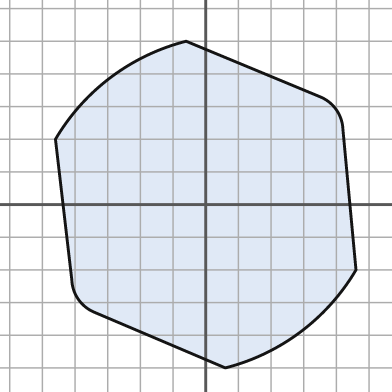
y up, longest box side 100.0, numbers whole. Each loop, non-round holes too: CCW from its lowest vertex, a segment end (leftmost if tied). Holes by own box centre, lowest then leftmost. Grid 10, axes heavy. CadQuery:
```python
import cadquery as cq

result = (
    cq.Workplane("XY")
    .moveTo(6.0, -50.0)
    .threePointArc((29.0, -39.0), (46.0, -20.0))
    .lineTo(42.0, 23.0)
    .threePointArc((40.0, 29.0), (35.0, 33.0))
    .lineTo(-6.0, 50.0)
    .threePointArc((-29.0, 39.0), (-46.0, 20.0))
    .lineTo(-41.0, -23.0)
    .threePointArc((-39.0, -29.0), (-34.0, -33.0))
    .close()
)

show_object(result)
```